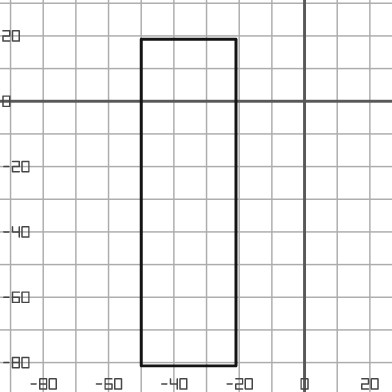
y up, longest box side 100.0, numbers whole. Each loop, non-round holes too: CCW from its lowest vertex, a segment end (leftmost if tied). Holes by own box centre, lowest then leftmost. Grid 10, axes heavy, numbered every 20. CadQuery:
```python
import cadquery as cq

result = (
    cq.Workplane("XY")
    .moveTo(-50.0, -81.0)
    .lineTo(-21.0, -81.0)
    .lineTo(-21.0, 19.0)
    .lineTo(-50.0, 19.0)
    .close()
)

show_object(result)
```